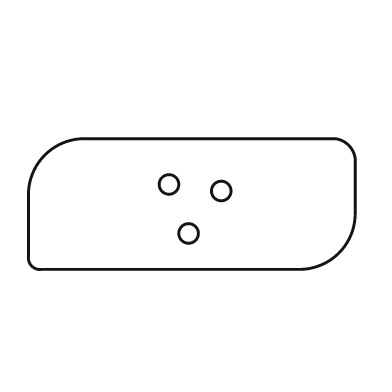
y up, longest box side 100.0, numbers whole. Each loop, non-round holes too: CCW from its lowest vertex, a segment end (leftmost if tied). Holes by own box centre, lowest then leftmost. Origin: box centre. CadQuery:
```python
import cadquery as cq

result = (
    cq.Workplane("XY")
    .moveTo(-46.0, -20.0)
    .lineTo(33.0, -20.0)
    .threePointArc((45.0, -15.0), (50.0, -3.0))
    .lineTo(50.0, 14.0)
    .threePointArc((48.0, 18.0), (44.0, 20.0))
    .lineTo(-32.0, 20.0)
    .threePointArc((-45.0, 15.0), (-50.0, 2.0))
    .lineTo(-50.0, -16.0)
    .threePointArc((-49.0, -19.0), (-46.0, -20.0))
    .close()
    .moveTo(-1.0, -9.0)
    .circle(3.0)
    .moveTo(9.0, 4.0)
    .circle(3.0)
    .moveTo(-7.0, 6.0)
    .circle(3.0)
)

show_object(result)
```